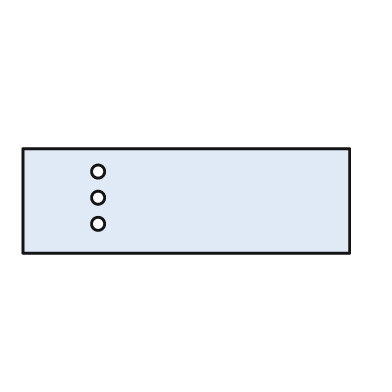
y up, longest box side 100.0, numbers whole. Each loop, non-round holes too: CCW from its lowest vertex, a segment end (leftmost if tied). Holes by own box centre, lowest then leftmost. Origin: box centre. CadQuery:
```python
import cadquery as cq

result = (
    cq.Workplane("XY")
    .moveTo(-50.0, -16.0)
    .lineTo(50.0, -16.0)
    .lineTo(50.0, 16.0)
    .lineTo(-50.0, 16.0)
    .close()
    .moveTo(-27.0, -7.0)
    .circle(2.0)
    .moveTo(-27.0, 1.0)
    .circle(2.0)
    .moveTo(-27.0, 9.0)
    .circle(2.0)
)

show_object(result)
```